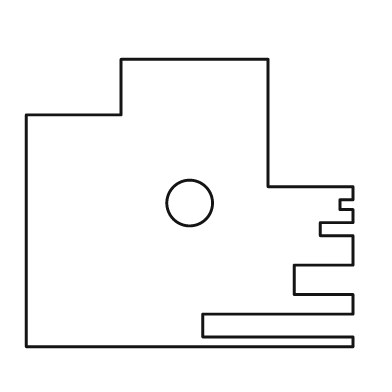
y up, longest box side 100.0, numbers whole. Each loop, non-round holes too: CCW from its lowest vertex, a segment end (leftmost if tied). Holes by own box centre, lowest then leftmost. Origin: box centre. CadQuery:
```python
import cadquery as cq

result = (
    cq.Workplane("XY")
    .moveTo(-50.0, -44.0)
    .lineTo(50.0, -44.0)
    .lineTo(50.0, -41.0)
    .lineTo(4.0, -41.0)
    .lineTo(4.0, -34.0)
    .lineTo(50.0, -34.0)
    .lineTo(50.0, -28.0)
    .lineTo(32.0, -28.0)
    .lineTo(32.0, -19.0)
    .lineTo(50.0, -19.0)
    .lineTo(50.0, -10.0)
    .lineTo(40.0, -10.0)
    .lineTo(40.0, -6.0)
    .lineTo(50.0, -6.0)
    .lineTo(50.0, -2.0)
    .lineTo(46.0, -2.0)
    .lineTo(46.0, 1.0)
    .lineTo(50.0, 1.0)
    .lineTo(50.0, 5.0)
    .lineTo(24.0, 5.0)
    .lineTo(24.0, 44.0)
    .lineTo(-21.0, 44.0)
    .lineTo(-21.0, 27.0)
    .lineTo(-50.0, 27.0)
    .close()
    .moveTo(0.0, 0.0)
    .circle(7.0)
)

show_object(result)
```